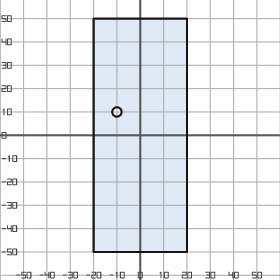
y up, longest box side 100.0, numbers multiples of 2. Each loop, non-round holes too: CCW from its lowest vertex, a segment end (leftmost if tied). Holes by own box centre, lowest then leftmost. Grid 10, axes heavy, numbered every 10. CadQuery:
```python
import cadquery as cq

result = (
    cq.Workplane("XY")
    .moveTo(-20.0, -50.0)
    .lineTo(20.0, -50.0)
    .lineTo(20.0, 50.0)
    .lineTo(-20.0, 50.0)
    .close()
    .moveTo(-10.0, 10.0)
    .circle(2.0)
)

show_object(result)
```